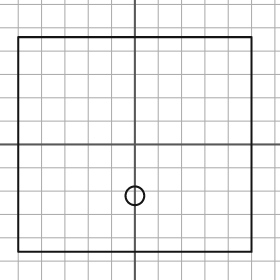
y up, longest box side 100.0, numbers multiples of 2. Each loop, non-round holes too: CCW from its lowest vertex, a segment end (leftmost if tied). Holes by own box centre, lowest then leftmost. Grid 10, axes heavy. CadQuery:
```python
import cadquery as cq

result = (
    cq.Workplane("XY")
    .moveTo(-50.0, -46.0)
    .lineTo(50.0, -46.0)
    .lineTo(50.0, 46.0)
    .lineTo(-50.0, 46.0)
    .close()
    .moveTo(0.0, -22.0)
    .circle(4.0)
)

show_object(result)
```